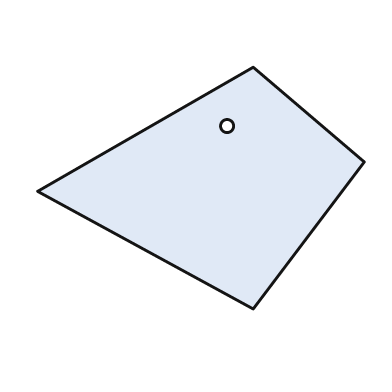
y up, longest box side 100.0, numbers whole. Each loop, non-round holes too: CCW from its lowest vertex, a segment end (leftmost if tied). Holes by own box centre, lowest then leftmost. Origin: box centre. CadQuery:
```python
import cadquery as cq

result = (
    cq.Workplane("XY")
    .moveTo(16.0, -37.0)
    .lineTo(50.0, 8.0)
    .lineTo(16.0, 37.0)
    .lineTo(-50.0, -1.0)
    .close()
    .moveTo(8.0, 19.0)
    .circle(2.0)
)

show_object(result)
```